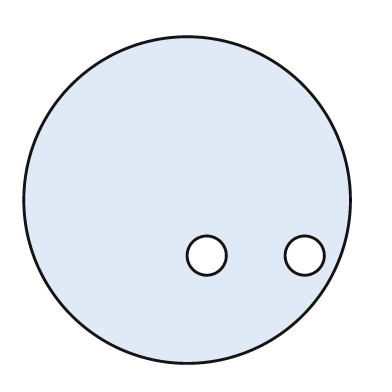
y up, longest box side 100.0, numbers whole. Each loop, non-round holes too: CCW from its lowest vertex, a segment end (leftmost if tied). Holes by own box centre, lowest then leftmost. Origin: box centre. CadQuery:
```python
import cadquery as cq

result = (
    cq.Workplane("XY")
    .moveTo(0.0, 0.0)
    .circle(50.0)
    .moveTo(6.0, -17.0)
    .circle(6.0)
    .moveTo(36.0, -17.0)
    .circle(6.0)
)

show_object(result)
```